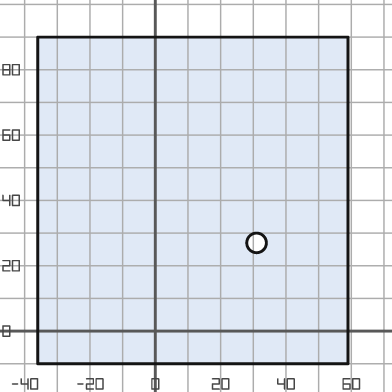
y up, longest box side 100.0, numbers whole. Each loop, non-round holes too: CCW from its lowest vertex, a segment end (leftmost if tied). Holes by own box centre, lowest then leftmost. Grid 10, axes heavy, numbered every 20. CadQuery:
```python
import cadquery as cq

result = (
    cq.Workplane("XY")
    .moveTo(-36.0, -10.0)
    .lineTo(59.0, -10.0)
    .lineTo(59.0, 90.0)
    .lineTo(-36.0, 90.0)
    .close()
    .moveTo(31.0, 27.0)
    .circle(3.0)
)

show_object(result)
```